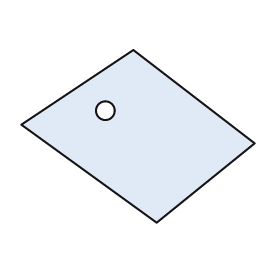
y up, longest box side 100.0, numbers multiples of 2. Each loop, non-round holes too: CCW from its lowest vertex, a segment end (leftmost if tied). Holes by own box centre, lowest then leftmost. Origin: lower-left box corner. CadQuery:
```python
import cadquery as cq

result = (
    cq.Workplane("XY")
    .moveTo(58.0, 0.0)
    .lineTo(100.0, 34.0)
    .lineTo(48.0, 74.0)
    .lineTo(0.0, 42.0)
    .close()
    .moveTo(36.0, 48.0)
    .circle(4.0)
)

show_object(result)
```